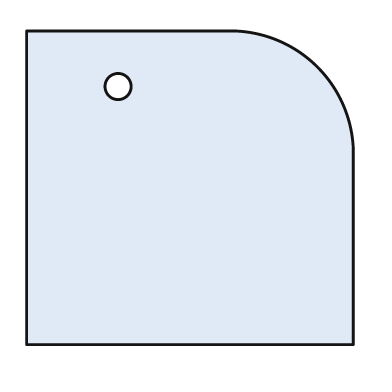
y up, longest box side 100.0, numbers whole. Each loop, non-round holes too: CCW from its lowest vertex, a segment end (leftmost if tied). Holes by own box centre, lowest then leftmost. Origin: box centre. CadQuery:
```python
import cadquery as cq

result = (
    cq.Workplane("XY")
    .moveTo(-50.0, -48.0)
    .lineTo(50.0, -48.0)
    .lineTo(50.0, 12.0)
    .threePointArc((39.0, 37.0), (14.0, 48.0))
    .lineTo(-50.0, 48.0)
    .close()
    .moveTo(-22.0, 31.0)
    .circle(4.0)
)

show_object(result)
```